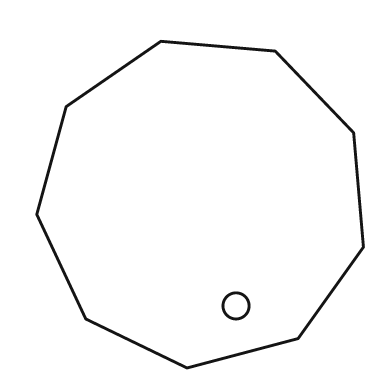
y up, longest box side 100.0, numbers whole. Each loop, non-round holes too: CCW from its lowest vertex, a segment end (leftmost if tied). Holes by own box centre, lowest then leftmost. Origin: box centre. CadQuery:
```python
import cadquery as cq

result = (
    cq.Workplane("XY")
    .moveTo(-4.0, -50.0)
    .lineTo(30.0, -41.0)
    .lineTo(50.0, -13.0)
    .lineTo(47.0, 22.0)
    .lineTo(23.0, 47.0)
    .lineTo(-12.0, 50.0)
    .lineTo(-41.0, 30.0)
    .lineTo(-50.0, -3.0)
    .lineTo(-35.0, -35.0)
    .close()
    .moveTo(11.0, -31.0)
    .circle(4.0)
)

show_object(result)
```